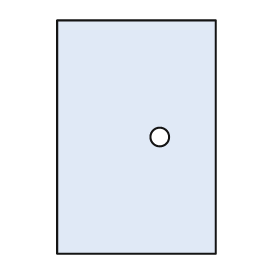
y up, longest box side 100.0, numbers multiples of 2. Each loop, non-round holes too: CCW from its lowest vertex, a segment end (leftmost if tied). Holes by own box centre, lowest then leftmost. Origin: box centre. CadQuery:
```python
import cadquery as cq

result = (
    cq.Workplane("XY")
    .moveTo(-34.0, -50.0)
    .lineTo(34.0, -50.0)
    .lineTo(34.0, 50.0)
    .lineTo(-34.0, 50.0)
    .close()
    .moveTo(10.0, 0.0)
    .circle(4.0)
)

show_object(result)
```